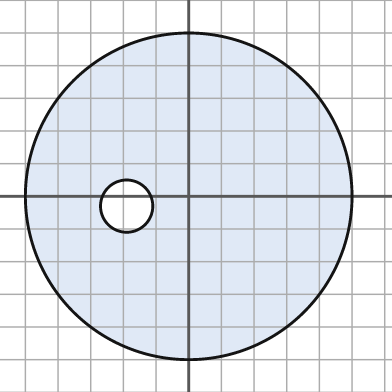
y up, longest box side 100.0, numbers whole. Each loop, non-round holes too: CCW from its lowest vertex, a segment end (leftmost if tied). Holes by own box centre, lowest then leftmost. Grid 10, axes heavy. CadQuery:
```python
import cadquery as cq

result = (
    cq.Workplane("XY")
    .moveTo(0.0, 0.0)
    .circle(50.0)
    .moveTo(-19.0, -3.0)
    .circle(8.0)
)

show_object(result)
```